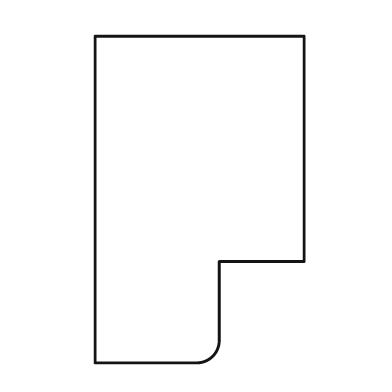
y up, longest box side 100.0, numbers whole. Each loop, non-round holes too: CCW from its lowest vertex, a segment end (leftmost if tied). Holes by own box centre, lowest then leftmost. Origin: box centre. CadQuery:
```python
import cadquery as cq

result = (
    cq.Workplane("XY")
    .moveTo(-32.0, -50.0)
    .lineTo(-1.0, -50.0)
    .threePointArc((4.0, -48.0), (6.0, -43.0))
    .lineTo(6.0, -19.0)
    .lineTo(32.0, -19.0)
    .lineTo(32.0, 50.0)
    .lineTo(-32.0, 50.0)
    .close()
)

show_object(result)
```